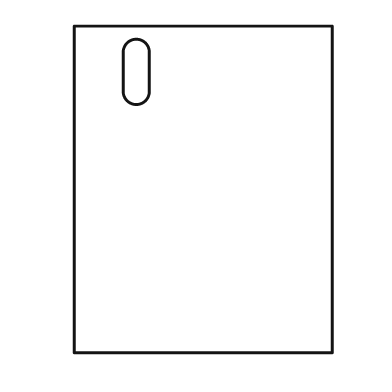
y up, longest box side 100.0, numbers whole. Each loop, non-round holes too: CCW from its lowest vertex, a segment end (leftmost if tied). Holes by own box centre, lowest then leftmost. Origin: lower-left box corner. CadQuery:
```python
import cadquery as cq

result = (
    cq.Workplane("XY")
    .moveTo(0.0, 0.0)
    .lineTo(79.0, 0.0)
    .lineTo(79.0, 100.0)
    .lineTo(0.0, 100.0)
    .close()
    .moveTo(15.0, 80.0)
    .threePointArc((19.0, 76.0), (23.0, 80.0))
    .lineTo(23.0, 92.0)
    .threePointArc((19.0, 96.0), (15.0, 92.0))
    .close()
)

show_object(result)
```